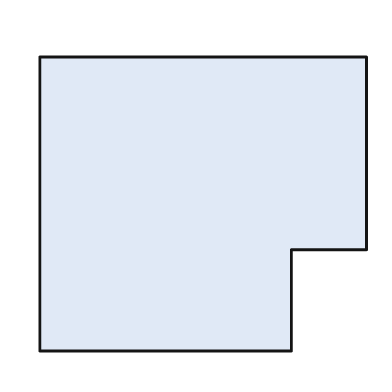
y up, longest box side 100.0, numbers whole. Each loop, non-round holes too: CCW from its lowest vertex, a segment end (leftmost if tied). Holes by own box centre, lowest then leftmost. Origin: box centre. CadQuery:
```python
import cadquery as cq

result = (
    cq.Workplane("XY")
    .moveTo(-50.0, -45.0)
    .lineTo(27.0, -45.0)
    .lineTo(27.0, -14.0)
    .lineTo(50.0, -14.0)
    .lineTo(50.0, 45.0)
    .lineTo(-50.0, 45.0)
    .close()
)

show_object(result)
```